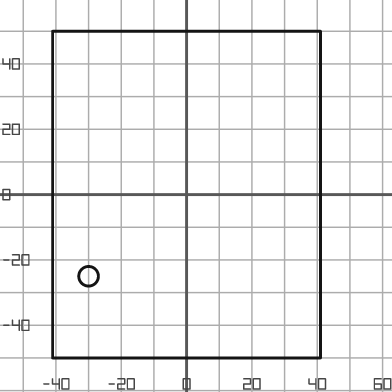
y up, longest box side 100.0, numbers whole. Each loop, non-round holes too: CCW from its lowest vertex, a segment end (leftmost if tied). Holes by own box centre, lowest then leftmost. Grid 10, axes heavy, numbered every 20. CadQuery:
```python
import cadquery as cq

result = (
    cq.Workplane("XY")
    .moveTo(-41.0, -50.0)
    .lineTo(41.0, -50.0)
    .lineTo(41.0, 50.0)
    .lineTo(-41.0, 50.0)
    .close()
    .moveTo(-30.0, -25.0)
    .circle(3.0)
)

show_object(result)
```